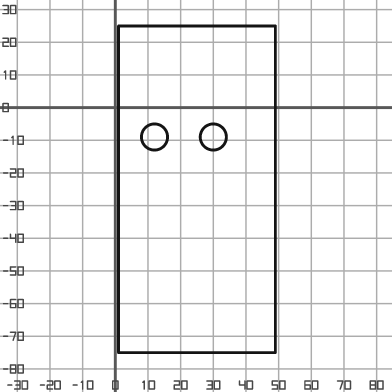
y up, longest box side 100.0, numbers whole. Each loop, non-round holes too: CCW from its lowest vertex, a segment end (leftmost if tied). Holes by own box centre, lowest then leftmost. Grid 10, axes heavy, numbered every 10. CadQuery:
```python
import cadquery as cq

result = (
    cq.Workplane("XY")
    .moveTo(1.0, -75.0)
    .lineTo(49.0, -75.0)
    .lineTo(49.0, 25.0)
    .lineTo(1.0, 25.0)
    .close()
    .moveTo(12.0, -9.0)
    .circle(4.0)
    .moveTo(30.0, -9.0)
    .circle(4.0)
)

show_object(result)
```